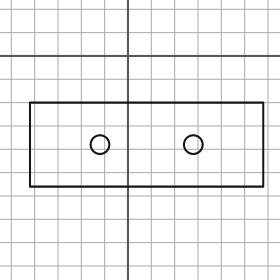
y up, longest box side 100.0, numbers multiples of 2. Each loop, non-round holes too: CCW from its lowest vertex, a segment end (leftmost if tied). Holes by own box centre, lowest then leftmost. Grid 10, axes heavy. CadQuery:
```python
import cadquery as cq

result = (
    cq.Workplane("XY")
    .moveTo(-42.0, -56.0)
    .lineTo(58.0, -56.0)
    .lineTo(58.0, -20.0)
    .lineTo(-42.0, -20.0)
    .close()
    .moveTo(-12.0, -38.0)
    .circle(4.0)
    .moveTo(28.0, -38.0)
    .circle(4.0)
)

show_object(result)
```